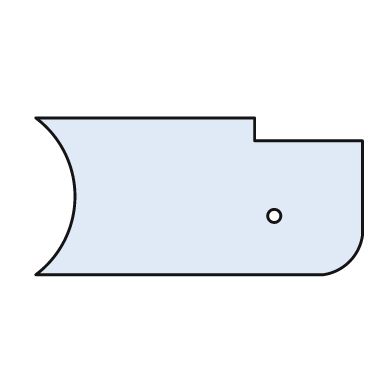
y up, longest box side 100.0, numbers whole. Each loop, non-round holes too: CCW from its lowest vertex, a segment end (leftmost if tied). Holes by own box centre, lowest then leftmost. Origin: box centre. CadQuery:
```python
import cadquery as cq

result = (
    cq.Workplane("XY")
    .moveTo(-50.0, -24.0)
    .lineTo(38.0, -24.0)
    .threePointArc((46.0, -20.0), (50.0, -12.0))
    .lineTo(50.0, 17.0)
    .lineTo(17.0, 17.0)
    .lineTo(17.0, 24.0)
    .lineTo(-50.0, 24.0)
    .threePointArc((-38.0, 0.0), (-50.0, -24.0))
    .close()
    .moveTo(23.0, -6.0)
    .circle(2.0)
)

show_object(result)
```